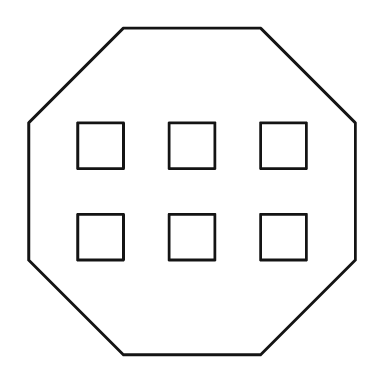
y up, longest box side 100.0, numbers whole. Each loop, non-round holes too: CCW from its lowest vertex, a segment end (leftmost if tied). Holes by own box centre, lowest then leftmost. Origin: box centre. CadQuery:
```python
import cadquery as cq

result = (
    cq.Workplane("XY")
    .moveTo(-21.0, -50.0)
    .lineTo(21.0, -50.0)
    .lineTo(50.0, -21.0)
    .lineTo(50.0, 21.0)
    .lineTo(21.0, 50.0)
    .lineTo(-21.0, 50.0)
    .lineTo(-50.0, 21.0)
    .lineTo(-50.0, -21.0)
    .close()
    .moveTo(-35.0, -21.0)
    .lineTo(-21.0, -21.0)
    .lineTo(-21.0, -7.0)
    .lineTo(-35.0, -7.0)
    .close()
    .moveTo(-7.0, -21.0)
    .lineTo(7.0, -21.0)
    .lineTo(7.0, -7.0)
    .lineTo(-7.0, -7.0)
    .close()
    .moveTo(21.0, -21.0)
    .lineTo(35.0, -21.0)
    .lineTo(35.0, -7.0)
    .lineTo(21.0, -7.0)
    .close()
    .moveTo(-35.0, 7.0)
    .lineTo(-21.0, 7.0)
    .lineTo(-21.0, 21.0)
    .lineTo(-35.0, 21.0)
    .close()
    .moveTo(-7.0, 7.0)
    .lineTo(7.0, 7.0)
    .lineTo(7.0, 21.0)
    .lineTo(-7.0, 21.0)
    .close()
    .moveTo(21.0, 7.0)
    .lineTo(35.0, 7.0)
    .lineTo(35.0, 21.0)
    .lineTo(21.0, 21.0)
    .close()
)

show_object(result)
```